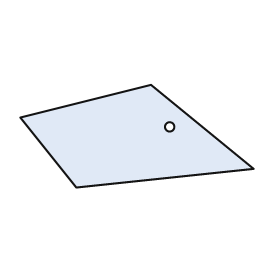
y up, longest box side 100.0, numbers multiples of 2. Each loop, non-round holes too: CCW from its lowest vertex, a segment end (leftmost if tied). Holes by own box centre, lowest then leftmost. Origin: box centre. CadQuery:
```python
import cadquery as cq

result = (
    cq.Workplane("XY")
    .moveTo(-26.0, -22.0)
    .lineTo(50.0, -14.0)
    .lineTo(6.0, 22.0)
    .lineTo(-50.0, 8.0)
    .close()
    .moveTo(14.0, 4.0)
    .circle(2.0)
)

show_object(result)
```